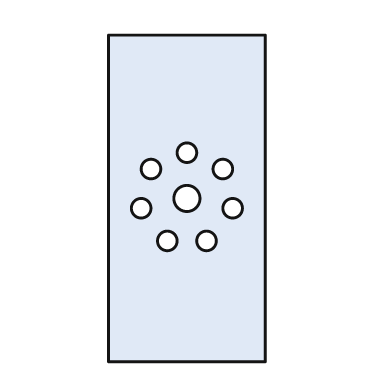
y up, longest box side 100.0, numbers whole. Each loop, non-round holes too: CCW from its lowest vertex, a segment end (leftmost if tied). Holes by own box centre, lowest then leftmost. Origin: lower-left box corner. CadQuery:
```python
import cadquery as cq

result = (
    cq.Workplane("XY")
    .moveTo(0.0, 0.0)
    .lineTo(48.0, 0.0)
    .lineTo(48.0, 100.0)
    .lineTo(0.0, 100.0)
    .close()
    .moveTo(18.0, 37.0)
    .circle(3.0)
    .moveTo(30.0, 37.0)
    .circle(3.0)
    .moveTo(10.0, 47.0)
    .circle(3.0)
    .moveTo(38.0, 47.0)
    .circle(3.0)
    .moveTo(24.0, 50.0)
    .circle(4.0)
    .moveTo(13.0, 59.0)
    .circle(3.0)
    .moveTo(35.0, 59.0)
    .circle(3.0)
    .moveTo(24.0, 64.0)
    .circle(3.0)
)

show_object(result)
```